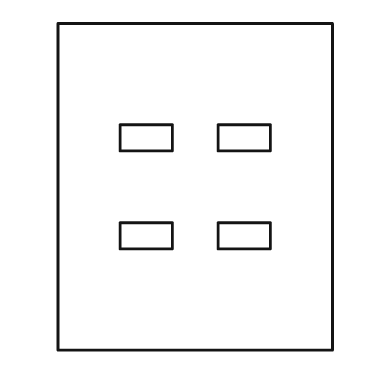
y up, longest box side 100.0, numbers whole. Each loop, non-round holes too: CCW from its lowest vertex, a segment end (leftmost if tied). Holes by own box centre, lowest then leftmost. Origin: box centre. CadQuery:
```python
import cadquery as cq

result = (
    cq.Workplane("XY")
    .moveTo(-42.0, -50.0)
    .lineTo(42.0, -50.0)
    .lineTo(42.0, 50.0)
    .lineTo(-42.0, 50.0)
    .close()
    .moveTo(-23.0, -19.0)
    .lineTo(-7.0, -19.0)
    .lineTo(-7.0, -11.0)
    .lineTo(-23.0, -11.0)
    .close()
    .moveTo(7.0, -19.0)
    .lineTo(23.0, -19.0)
    .lineTo(23.0, -11.0)
    .lineTo(7.0, -11.0)
    .close()
    .moveTo(-23.0, 11.0)
    .lineTo(-7.0, 11.0)
    .lineTo(-7.0, 19.0)
    .lineTo(-23.0, 19.0)
    .close()
    .moveTo(7.0, 11.0)
    .lineTo(23.0, 11.0)
    .lineTo(23.0, 19.0)
    .lineTo(7.0, 19.0)
    .close()
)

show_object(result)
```